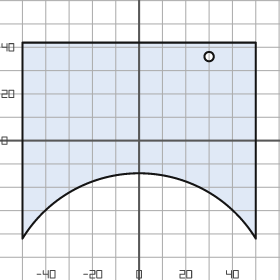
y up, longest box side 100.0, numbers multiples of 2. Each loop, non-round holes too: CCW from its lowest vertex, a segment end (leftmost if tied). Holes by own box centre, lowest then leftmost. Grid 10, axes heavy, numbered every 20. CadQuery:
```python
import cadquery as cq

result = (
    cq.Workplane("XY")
    .moveTo(-50.0, -42.0)
    .threePointArc((0.0, -14.0), (50.0, -42.0))
    .lineTo(50.0, 42.0)
    .lineTo(-50.0, 42.0)
    .close()
    .moveTo(30.0, 36.0)
    .circle(2.0)
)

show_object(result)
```